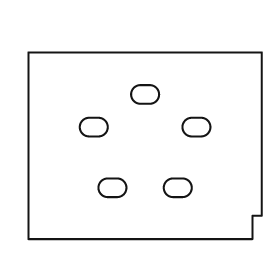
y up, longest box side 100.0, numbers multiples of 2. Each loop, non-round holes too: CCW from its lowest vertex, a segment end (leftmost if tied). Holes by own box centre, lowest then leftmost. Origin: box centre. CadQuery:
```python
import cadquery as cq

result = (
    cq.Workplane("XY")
    .moveTo(-50.0, -40.0)
    .lineTo(46.0, -40.0)
    .lineTo(46.0, -30.0)
    .lineTo(50.0, -30.0)
    .lineTo(50.0, 40.0)
    .lineTo(-50.0, 40.0)
    .close()
    .moveTo(-16.0, -22.0)
    .lineTo(-12.0, -22.0)
    .threePointArc((-8.0, -18.0), (-12.0, -14.0))
    .lineTo(-16.0, -14.0)
    .threePointArc((-20.0, -18.0), (-16.0, -22.0))
    .close()
    .moveTo(12.0, -22.0)
    .lineTo(16.0, -22.0)
    .threePointArc((20.0, -18.0), (16.0, -14.0))
    .lineTo(12.0, -14.0)
    .threePointArc((8.0, -18.0), (12.0, -22.0))
    .close()
    .moveTo(-24.0, 4.0)
    .lineTo(-20.0, 4.0)
    .threePointArc((-16.0, 8.0), (-20.0, 12.0))
    .lineTo(-24.0, 12.0)
    .threePointArc((-28.0, 8.0), (-24.0, 4.0))
    .close()
    .moveTo(20.0, 4.0)
    .lineTo(24.0, 4.0)
    .threePointArc((28.0, 8.0), (24.0, 12.0))
    .lineTo(20.0, 12.0)
    .threePointArc((16.0, 8.0), (20.0, 4.0))
    .close()
    .moveTo(-2.0, 18.0)
    .lineTo(2.0, 18.0)
    .threePointArc((6.0, 22.0), (2.0, 26.0))
    .lineTo(-2.0, 26.0)
    .threePointArc((-6.0, 22.0), (-2.0, 18.0))
    .close()
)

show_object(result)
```